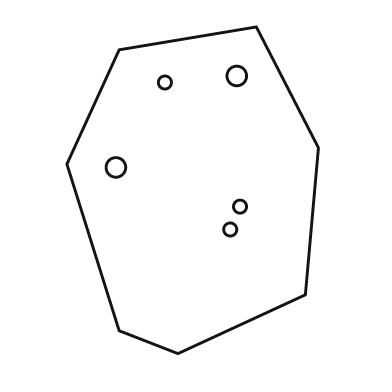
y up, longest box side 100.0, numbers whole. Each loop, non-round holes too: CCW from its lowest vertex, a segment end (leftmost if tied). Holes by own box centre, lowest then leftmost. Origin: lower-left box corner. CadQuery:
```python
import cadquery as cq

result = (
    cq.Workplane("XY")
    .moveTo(34.0, 0.0)
    .lineTo(73.0, 18.0)
    .lineTo(77.0, 63.0)
    .lineTo(58.0, 100.0)
    .lineTo(16.0, 93.0)
    .lineTo(0.0, 58.0)
    .lineTo(16.0, 7.0)
    .close()
    .moveTo(50.0, 38.0)
    .circle(2.0)
    .moveTo(53.0, 45.0)
    .circle(2.0)
    .moveTo(15.0, 57.0)
    .circle(3.0)
    .moveTo(30.0, 83.0)
    .circle(2.0)
    .moveTo(52.0, 85.0)
    .circle(3.0)
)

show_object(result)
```